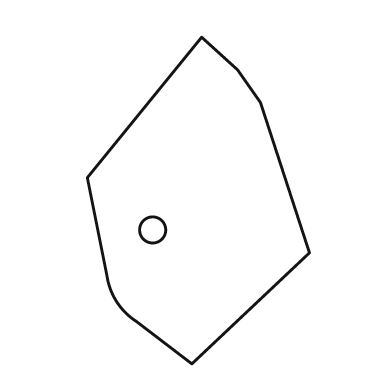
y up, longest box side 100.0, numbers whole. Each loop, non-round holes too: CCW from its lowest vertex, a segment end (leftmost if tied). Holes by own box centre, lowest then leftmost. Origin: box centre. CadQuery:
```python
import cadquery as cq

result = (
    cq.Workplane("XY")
    .moveTo(-2.0, -50.0)
    .lineTo(34.0, -16.0)
    .lineTo(19.0, 30.0)
    .lineTo(12.0, 40.0)
    .lineTo(1.0, 50.0)
    .lineTo(-34.0, 7.0)
    .lineTo(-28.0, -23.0)
    .threePointArc((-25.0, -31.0), (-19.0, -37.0))
    .close()
    .moveTo(-14.0, -9.0)
    .circle(4.0)
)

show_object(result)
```